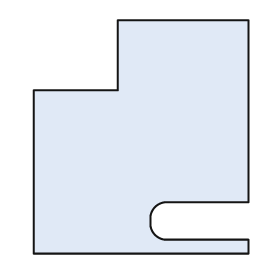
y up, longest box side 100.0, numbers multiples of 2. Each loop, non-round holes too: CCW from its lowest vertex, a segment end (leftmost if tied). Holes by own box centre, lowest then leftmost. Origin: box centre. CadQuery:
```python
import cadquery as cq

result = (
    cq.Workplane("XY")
    .moveTo(-46.0, -50.0)
    .lineTo(46.0, -50.0)
    .lineTo(46.0, -44.0)
    .lineTo(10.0, -44.0)
    .threePointArc((6.0, -42.0), (4.0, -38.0))
    .lineTo(4.0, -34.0)
    .threePointArc((6.0, -30.0), (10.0, -28.0))
    .lineTo(46.0, -28.0)
    .lineTo(46.0, 50.0)
    .lineTo(-10.0, 50.0)
    .lineTo(-10.0, 20.0)
    .lineTo(-46.0, 20.0)
    .close()
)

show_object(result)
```